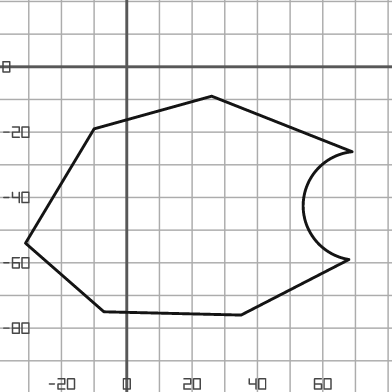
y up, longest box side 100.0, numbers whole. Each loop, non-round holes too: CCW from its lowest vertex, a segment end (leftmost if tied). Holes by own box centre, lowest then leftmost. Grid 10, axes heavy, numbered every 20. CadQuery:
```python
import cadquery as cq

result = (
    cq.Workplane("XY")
    .moveTo(35.0, -76.0)
    .lineTo(68.0, -59.0)
    .threePointArc((54.0, -42.0), (69.0, -26.0))
    .lineTo(26.0, -9.0)
    .lineTo(-10.0, -19.0)
    .lineTo(-31.0, -54.0)
    .lineTo(-7.0, -75.0)
    .close()
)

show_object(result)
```